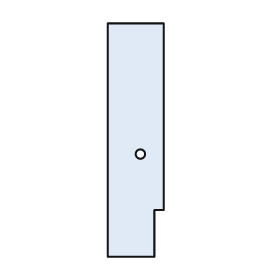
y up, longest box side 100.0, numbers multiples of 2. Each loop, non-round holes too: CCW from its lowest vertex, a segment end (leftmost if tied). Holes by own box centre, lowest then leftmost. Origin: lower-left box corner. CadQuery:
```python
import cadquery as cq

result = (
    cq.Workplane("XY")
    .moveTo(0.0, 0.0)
    .lineTo(20.0, 0.0)
    .lineTo(20.0, 20.0)
    .lineTo(24.0, 20.0)
    .lineTo(24.0, 100.0)
    .lineTo(0.0, 100.0)
    .close()
    .moveTo(14.0, 44.0)
    .circle(2.0)
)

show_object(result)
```